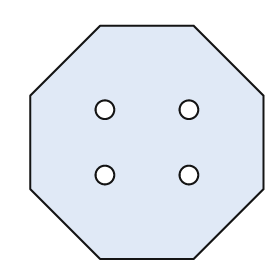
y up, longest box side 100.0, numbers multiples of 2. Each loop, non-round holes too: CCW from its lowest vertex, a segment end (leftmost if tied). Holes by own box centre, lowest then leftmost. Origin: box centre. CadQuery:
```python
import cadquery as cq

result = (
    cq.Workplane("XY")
    .moveTo(-20.0, -50.0)
    .lineTo(20.0, -50.0)
    .lineTo(50.0, -20.0)
    .lineTo(50.0, 20.0)
    .lineTo(20.0, 50.0)
    .lineTo(-20.0, 50.0)
    .lineTo(-50.0, 20.0)
    .lineTo(-50.0, -20.0)
    .close()
    .moveTo(-18.0, -14.0)
    .circle(4.0)
    .moveTo(18.0, -14.0)
    .circle(4.0)
    .moveTo(-18.0, 14.0)
    .circle(4.0)
    .moveTo(18.0, 14.0)
    .circle(4.0)
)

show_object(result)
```